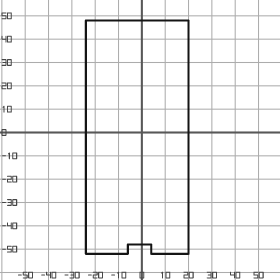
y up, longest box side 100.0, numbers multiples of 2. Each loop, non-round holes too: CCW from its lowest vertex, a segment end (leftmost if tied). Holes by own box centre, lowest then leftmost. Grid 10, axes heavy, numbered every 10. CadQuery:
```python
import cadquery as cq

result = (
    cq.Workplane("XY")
    .moveTo(-24.0, -52.0)
    .lineTo(-6.0, -52.0)
    .lineTo(-6.0, -48.0)
    .lineTo(4.0, -48.0)
    .lineTo(4.0, -52.0)
    .lineTo(20.0, -52.0)
    .lineTo(20.0, 48.0)
    .lineTo(-24.0, 48.0)
    .close()
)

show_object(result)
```